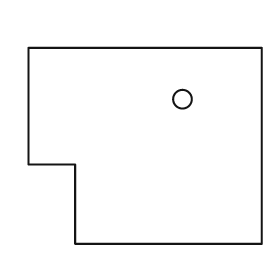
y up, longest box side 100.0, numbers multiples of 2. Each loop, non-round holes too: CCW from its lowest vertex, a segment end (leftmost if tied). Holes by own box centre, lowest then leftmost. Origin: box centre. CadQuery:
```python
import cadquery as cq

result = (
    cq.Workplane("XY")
    .moveTo(-30.0, -42.0)
    .lineTo(50.0, -42.0)
    .lineTo(50.0, 42.0)
    .lineTo(-50.0, 42.0)
    .lineTo(-50.0, -8.0)
    .lineTo(-30.0, -8.0)
    .close()
    .moveTo(16.0, 20.0)
    .circle(4.0)
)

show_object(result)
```